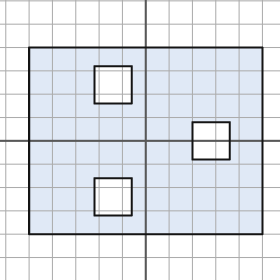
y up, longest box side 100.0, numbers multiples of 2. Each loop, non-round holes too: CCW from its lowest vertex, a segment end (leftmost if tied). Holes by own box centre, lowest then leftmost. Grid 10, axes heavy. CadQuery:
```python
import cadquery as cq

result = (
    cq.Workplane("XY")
    .moveTo(-50.0, -40.0)
    .lineTo(50.0, -40.0)
    .lineTo(50.0, 40.0)
    .lineTo(-50.0, 40.0)
    .close()
    .moveTo(-22.0, -32.0)
    .lineTo(-6.0, -32.0)
    .lineTo(-6.0, -16.0)
    .lineTo(-22.0, -16.0)
    .close()
    .moveTo(20.0, -8.0)
    .lineTo(36.0, -8.0)
    .lineTo(36.0, 8.0)
    .lineTo(20.0, 8.0)
    .close()
    .moveTo(-22.0, 16.0)
    .lineTo(-6.0, 16.0)
    .lineTo(-6.0, 32.0)
    .lineTo(-22.0, 32.0)
    .close()
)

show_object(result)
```